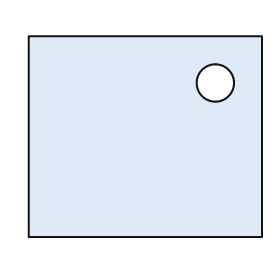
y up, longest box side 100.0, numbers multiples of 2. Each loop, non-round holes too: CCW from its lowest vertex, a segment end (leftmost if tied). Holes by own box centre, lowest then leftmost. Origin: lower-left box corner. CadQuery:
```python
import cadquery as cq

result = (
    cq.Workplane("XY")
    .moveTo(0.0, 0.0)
    .lineTo(100.0, 0.0)
    .lineTo(100.0, 86.0)
    .lineTo(0.0, 86.0)
    .close()
    .moveTo(80.0, 66.0)
    .circle(8.0)
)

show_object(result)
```